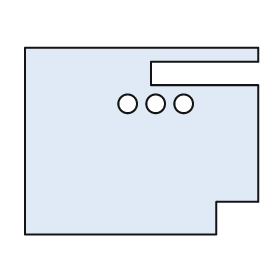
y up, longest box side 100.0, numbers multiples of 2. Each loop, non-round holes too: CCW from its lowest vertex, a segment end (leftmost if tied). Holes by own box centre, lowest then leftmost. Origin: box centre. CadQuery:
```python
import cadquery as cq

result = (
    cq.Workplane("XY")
    .moveTo(-50.0, -40.0)
    .lineTo(32.0, -40.0)
    .lineTo(32.0, -26.0)
    .lineTo(50.0, -26.0)
    .lineTo(50.0, 24.0)
    .lineTo(4.0, 24.0)
    .lineTo(4.0, 34.0)
    .lineTo(50.0, 34.0)
    .lineTo(50.0, 40.0)
    .lineTo(-50.0, 40.0)
    .close()
    .moveTo(-6.0, 16.0)
    .circle(4.0)
    .moveTo(6.0, 16.0)
    .circle(4.0)
    .moveTo(18.0, 16.0)
    .circle(4.0)
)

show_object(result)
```